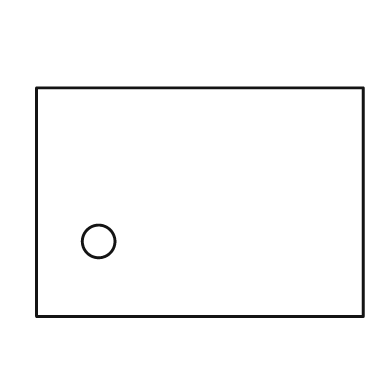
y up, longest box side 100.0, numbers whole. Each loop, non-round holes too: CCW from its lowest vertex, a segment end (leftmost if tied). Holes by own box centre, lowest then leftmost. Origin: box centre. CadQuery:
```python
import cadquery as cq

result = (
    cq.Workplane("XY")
    .moveTo(-50.0, -35.0)
    .lineTo(50.0, -35.0)
    .lineTo(50.0, 35.0)
    .lineTo(-50.0, 35.0)
    .close()
    .moveTo(-31.0, -12.0)
    .circle(5.0)
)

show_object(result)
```